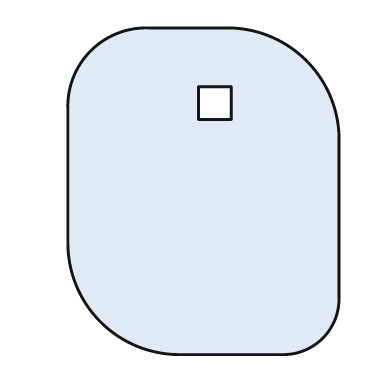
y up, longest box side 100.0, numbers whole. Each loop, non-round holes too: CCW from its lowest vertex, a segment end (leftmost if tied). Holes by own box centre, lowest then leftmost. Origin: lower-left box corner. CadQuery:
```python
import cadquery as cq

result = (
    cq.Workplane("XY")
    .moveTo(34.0, 0.0)
    .lineTo(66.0, 0.0)
    .threePointArc((78.0, 5.0), (83.0, 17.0))
    .lineTo(83.0, 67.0)
    .threePointArc((73.0, 90.0), (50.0, 100.0))
    .lineTo(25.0, 100.0)
    .threePointArc((7.0, 93.0), (0.0, 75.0))
    .lineTo(0.0, 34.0)
    .threePointArc((10.0, 10.0), (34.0, 0.0))
    .close()
    .moveTo(40.0, 72.0)
    .lineTo(50.0, 72.0)
    .lineTo(50.0, 82.0)
    .lineTo(40.0, 82.0)
    .close()
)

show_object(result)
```